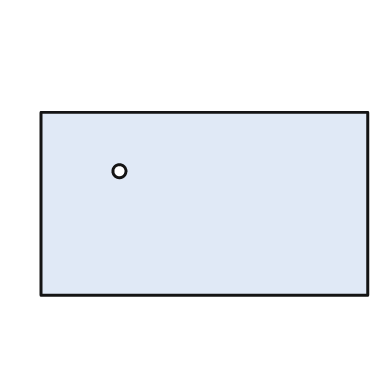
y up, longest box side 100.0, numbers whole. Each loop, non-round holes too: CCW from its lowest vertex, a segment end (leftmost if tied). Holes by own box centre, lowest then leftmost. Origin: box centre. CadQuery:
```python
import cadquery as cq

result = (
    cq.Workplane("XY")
    .moveTo(-50.0, -28.0)
    .lineTo(50.0, -28.0)
    .lineTo(50.0, 28.0)
    .lineTo(-50.0, 28.0)
    .close()
    .moveTo(-26.0, 10.0)
    .circle(2.0)
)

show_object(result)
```